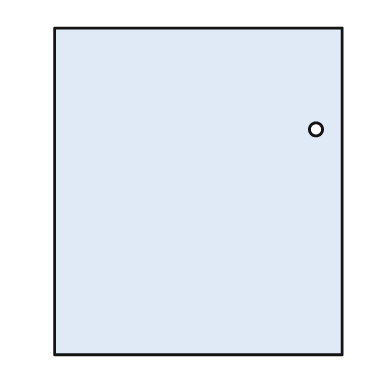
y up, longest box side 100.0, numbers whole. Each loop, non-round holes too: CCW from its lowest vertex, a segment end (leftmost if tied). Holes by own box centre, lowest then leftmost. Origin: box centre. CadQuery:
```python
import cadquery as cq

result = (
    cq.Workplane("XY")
    .moveTo(-44.0, -50.0)
    .lineTo(44.0, -50.0)
    .lineTo(44.0, 50.0)
    .lineTo(-44.0, 50.0)
    .close()
    .moveTo(36.0, 19.0)
    .circle(2.0)
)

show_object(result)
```